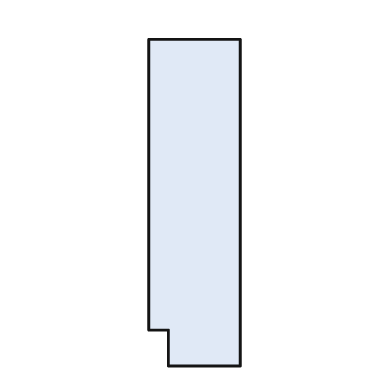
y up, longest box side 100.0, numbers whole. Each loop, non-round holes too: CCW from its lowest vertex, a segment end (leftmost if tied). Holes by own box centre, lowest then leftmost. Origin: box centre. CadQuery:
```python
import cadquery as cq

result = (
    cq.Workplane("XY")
    .moveTo(-8.0, -50.0)
    .lineTo(14.0, -50.0)
    .lineTo(14.0, 50.0)
    .lineTo(-14.0, 50.0)
    .lineTo(-14.0, -39.0)
    .lineTo(-8.0, -39.0)
    .close()
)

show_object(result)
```